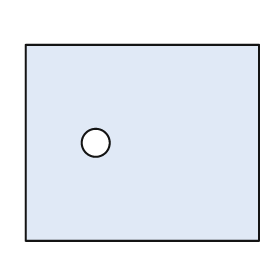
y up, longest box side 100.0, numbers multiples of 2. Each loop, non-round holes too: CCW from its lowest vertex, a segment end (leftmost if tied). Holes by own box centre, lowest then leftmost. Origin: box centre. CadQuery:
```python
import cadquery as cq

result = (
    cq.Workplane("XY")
    .moveTo(-50.0, -42.0)
    .lineTo(50.0, -42.0)
    .lineTo(50.0, 42.0)
    .lineTo(-50.0, 42.0)
    .close()
    .moveTo(-20.0, 0.0)
    .circle(6.0)
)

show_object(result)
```